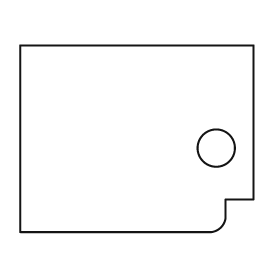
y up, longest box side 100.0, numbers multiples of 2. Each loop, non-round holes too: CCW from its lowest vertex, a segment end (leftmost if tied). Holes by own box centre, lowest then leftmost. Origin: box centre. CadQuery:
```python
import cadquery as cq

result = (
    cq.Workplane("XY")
    .moveTo(-50.0, -40.0)
    .lineTo(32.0, -40.0)
    .threePointArc((36.0, -38.0), (38.0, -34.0))
    .lineTo(38.0, -26.0)
    .lineTo(50.0, -26.0)
    .lineTo(50.0, 40.0)
    .lineTo(-50.0, 40.0)
    .close()
    .moveTo(34.0, -4.0)
    .circle(8.0)
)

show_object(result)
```